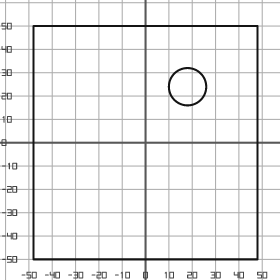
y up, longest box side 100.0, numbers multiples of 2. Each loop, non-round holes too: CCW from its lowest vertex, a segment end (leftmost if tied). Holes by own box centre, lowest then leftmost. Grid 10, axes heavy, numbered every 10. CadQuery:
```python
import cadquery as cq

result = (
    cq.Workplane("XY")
    .moveTo(-48.0, -50.0)
    .lineTo(48.0, -50.0)
    .lineTo(48.0, 50.0)
    .lineTo(-48.0, 50.0)
    .close()
    .moveTo(18.0, 24.0)
    .circle(8.0)
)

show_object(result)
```